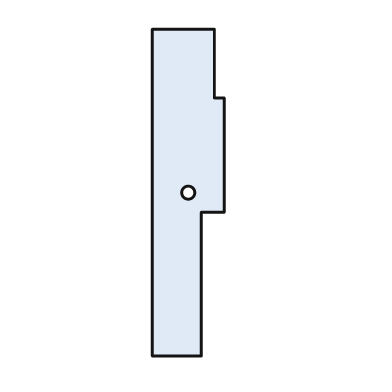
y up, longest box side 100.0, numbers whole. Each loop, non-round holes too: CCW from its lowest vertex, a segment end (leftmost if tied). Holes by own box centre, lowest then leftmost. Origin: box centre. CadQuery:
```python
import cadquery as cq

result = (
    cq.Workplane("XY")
    .moveTo(-11.0, -50.0)
    .lineTo(4.0, -50.0)
    .lineTo(4.0, -6.0)
    .lineTo(11.0, -6.0)
    .lineTo(11.0, 29.0)
    .lineTo(8.0, 29.0)
    .lineTo(8.0, 50.0)
    .lineTo(-11.0, 50.0)
    .close()
    .moveTo(0.0, 0.0)
    .circle(2.0)
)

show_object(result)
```